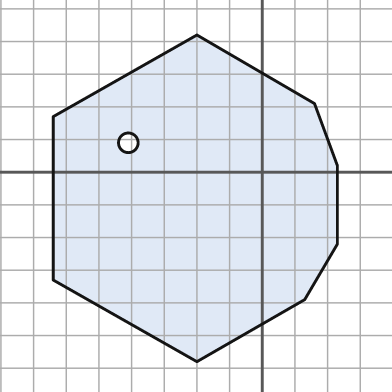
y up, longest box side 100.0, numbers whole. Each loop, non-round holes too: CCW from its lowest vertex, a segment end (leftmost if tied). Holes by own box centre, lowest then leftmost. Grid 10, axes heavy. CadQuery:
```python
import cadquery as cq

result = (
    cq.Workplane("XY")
    .moveTo(-20.0, -58.0)
    .lineTo(13.0, -39.0)
    .lineTo(23.0, -22.0)
    .lineTo(23.0, 2.0)
    .lineTo(16.0, 21.0)
    .lineTo(-20.0, 42.0)
    .lineTo(-64.0, 17.0)
    .lineTo(-64.0, -33.0)
    .close()
    .moveTo(-41.0, 9.0)
    .circle(3.0)
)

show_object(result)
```